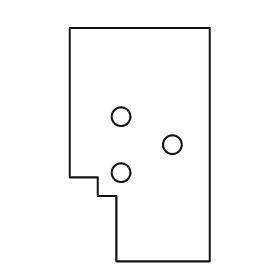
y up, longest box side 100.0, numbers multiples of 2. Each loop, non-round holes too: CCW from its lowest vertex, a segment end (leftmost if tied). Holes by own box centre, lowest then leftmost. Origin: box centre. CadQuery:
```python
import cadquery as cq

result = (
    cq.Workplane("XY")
    .moveTo(-10.0, -50.0)
    .lineTo(30.0, -50.0)
    .lineTo(30.0, 50.0)
    .lineTo(-30.0, 50.0)
    .lineTo(-30.0, -14.0)
    .lineTo(-18.0, -14.0)
    .lineTo(-18.0, -22.0)
    .lineTo(-10.0, -22.0)
    .close()
    .moveTo(-8.0, -12.0)
    .circle(4.0)
    .moveTo(14.0, 0.0)
    .circle(4.0)
    .moveTo(-8.0, 12.0)
    .circle(4.0)
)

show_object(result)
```